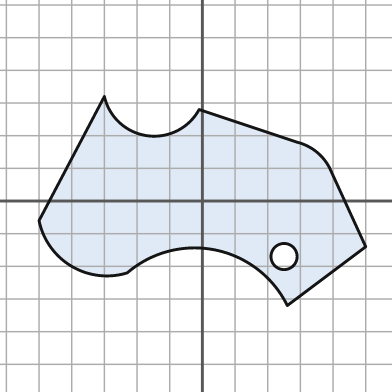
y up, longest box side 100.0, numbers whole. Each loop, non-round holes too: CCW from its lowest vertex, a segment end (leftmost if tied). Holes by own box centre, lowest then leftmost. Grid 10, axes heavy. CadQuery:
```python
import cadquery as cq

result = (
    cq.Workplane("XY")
    .moveTo(26.0, -32.0)
    .lineTo(50.0, -14.0)
    .lineTo(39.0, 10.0)
    .threePointArc((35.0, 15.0), (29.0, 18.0))
    .lineTo(-1.0, 28.0)
    .threePointArc((-17.0, 20.0), (-30.0, 32.0))
    .lineTo(-50.0, -6.0)
    .threePointArc((-40.0, -20.0), (-23.0, -22.0))
    .threePointArc((4.0, -15.0), (26.0, -32.0))
    .close()
    .moveTo(25.0, -17.0)
    .circle(4.0)
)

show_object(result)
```